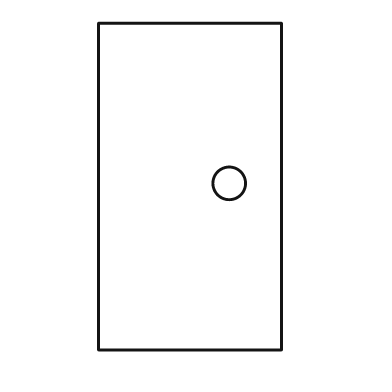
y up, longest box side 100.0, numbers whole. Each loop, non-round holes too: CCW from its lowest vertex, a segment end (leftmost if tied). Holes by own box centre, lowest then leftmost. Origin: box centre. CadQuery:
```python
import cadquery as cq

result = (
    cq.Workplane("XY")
    .moveTo(-28.0, -50.0)
    .lineTo(28.0, -50.0)
    .lineTo(28.0, 50.0)
    .lineTo(-28.0, 50.0)
    .close()
    .moveTo(12.0, 1.0)
    .circle(5.0)
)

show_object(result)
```